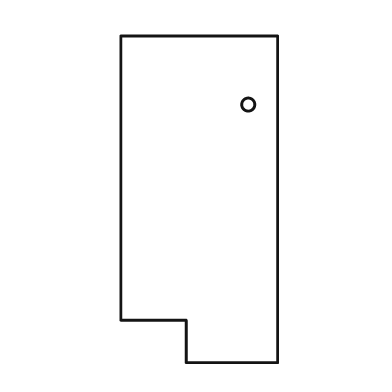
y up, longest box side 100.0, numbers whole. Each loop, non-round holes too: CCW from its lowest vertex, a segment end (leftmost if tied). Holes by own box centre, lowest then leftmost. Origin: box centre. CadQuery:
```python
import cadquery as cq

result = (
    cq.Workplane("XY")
    .moveTo(-4.0, -50.0)
    .lineTo(24.0, -50.0)
    .lineTo(24.0, 50.0)
    .lineTo(-24.0, 50.0)
    .lineTo(-24.0, -37.0)
    .lineTo(-4.0, -37.0)
    .close()
    .moveTo(15.0, 29.0)
    .circle(2.0)
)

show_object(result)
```